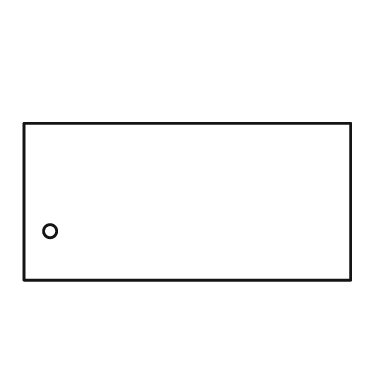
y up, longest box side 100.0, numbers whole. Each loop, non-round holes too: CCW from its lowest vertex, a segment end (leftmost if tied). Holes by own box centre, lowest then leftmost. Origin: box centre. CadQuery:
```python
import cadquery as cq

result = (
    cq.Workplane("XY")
    .moveTo(-50.0, -24.0)
    .lineTo(50.0, -24.0)
    .lineTo(50.0, 24.0)
    .lineTo(-50.0, 24.0)
    .close()
    .moveTo(-42.0, -9.0)
    .circle(2.0)
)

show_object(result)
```